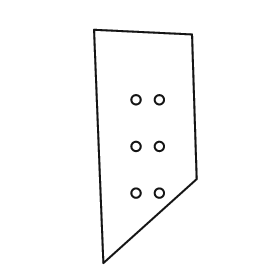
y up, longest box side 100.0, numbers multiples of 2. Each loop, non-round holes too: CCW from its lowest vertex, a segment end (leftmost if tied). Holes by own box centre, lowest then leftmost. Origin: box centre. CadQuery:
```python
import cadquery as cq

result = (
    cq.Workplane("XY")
    .moveTo(-18.0, -50.0)
    .lineTo(22.0, -14.0)
    .lineTo(20.0, 48.0)
    .lineTo(-22.0, 50.0)
    .close()
    .moveTo(-4.0, -20.0)
    .circle(2.0)
    .moveTo(6.0, -20.0)
    .circle(2.0)
    .moveTo(-4.0, 0.0)
    .circle(2.0)
    .moveTo(6.0, 0.0)
    .circle(2.0)
    .moveTo(-4.0, 20.0)
    .circle(2.0)
    .moveTo(6.0, 20.0)
    .circle(2.0)
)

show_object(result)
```